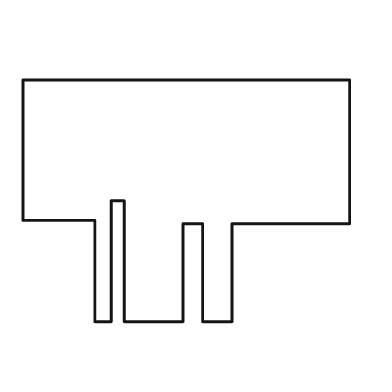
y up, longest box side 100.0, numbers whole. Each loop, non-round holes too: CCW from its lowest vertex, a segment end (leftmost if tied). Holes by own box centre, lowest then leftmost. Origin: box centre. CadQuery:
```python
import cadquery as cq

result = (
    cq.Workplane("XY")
    .moveTo(-28.0, -37.0)
    .lineTo(-23.0, -37.0)
    .lineTo(-23.0, 0.0)
    .lineTo(-19.0, 0.0)
    .lineTo(-19.0, -37.0)
    .lineTo(-1.0, -37.0)
    .lineTo(-1.0, -7.0)
    .lineTo(5.0, -7.0)
    .lineTo(5.0, -37.0)
    .lineTo(14.0, -37.0)
    .lineTo(14.0, -7.0)
    .lineTo(50.0, -7.0)
    .lineTo(50.0, 37.0)
    .lineTo(-50.0, 37.0)
    .lineTo(-50.0, -6.0)
    .lineTo(-28.0, -6.0)
    .close()
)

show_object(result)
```